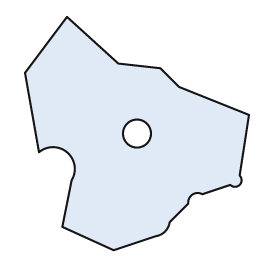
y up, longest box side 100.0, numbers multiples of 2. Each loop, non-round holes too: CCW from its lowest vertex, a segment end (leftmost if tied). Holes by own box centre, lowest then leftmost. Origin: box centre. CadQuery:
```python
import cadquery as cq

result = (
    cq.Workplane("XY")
    .moveTo(-10.0, -50.0)
    .lineTo(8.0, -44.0)
    .threePointArc((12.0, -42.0), (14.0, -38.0))
    .lineTo(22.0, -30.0)
    .threePointArc((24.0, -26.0), (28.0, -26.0))
    .lineTo(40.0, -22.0)
    .threePointArc((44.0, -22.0), (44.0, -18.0))
    .lineTo(48.0, 8.0)
    .lineTo(18.0, 20.0)
    .lineTo(10.0, 28.0)
    .lineTo(-8.0, 30.0)
    .lineTo(-30.0, 50.0)
    .lineTo(-48.0, 26.0)
    .lineTo(-42.0, -8.0)
    .threePointArc((-30.0, -8.0), (-28.0, -20.0))
    .lineTo(-32.0, -40.0)
    .close()
    .moveTo(0.0, 0.0)
    .circle(6.0)
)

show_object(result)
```